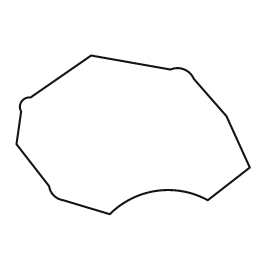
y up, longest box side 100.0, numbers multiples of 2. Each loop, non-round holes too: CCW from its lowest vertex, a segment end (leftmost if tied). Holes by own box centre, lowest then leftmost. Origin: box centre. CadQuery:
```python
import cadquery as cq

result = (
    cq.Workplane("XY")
    .moveTo(-10.0, -34.0)
    .threePointArc((10.0, -24.0), (32.0, -28.0))
    .lineTo(50.0, -14.0)
    .lineTo(40.0, 8.0)
    .lineTo(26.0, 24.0)
    .threePointArc((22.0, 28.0), (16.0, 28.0))
    .lineTo(-18.0, 34.0)
    .lineTo(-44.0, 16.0)
    .threePointArc((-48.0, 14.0), (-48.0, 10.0))
    .lineTo(-50.0, -4.0)
    .lineTo(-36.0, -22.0)
    .threePointArc((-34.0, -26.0), (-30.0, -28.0))
    .close()
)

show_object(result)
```